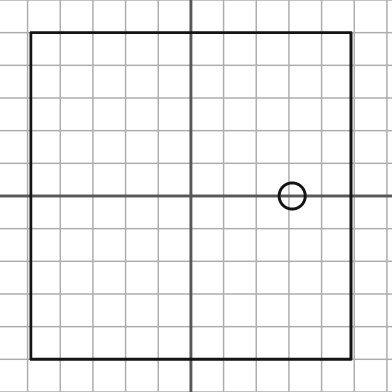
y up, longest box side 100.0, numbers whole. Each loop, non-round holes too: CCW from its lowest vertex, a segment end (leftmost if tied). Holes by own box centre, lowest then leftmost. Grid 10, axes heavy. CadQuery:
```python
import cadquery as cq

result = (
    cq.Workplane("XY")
    .moveTo(-49.0, -50.0)
    .lineTo(49.0, -50.0)
    .lineTo(49.0, 50.0)
    .lineTo(-49.0, 50.0)
    .close()
    .moveTo(31.0, 0.0)
    .circle(4.0)
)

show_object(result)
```